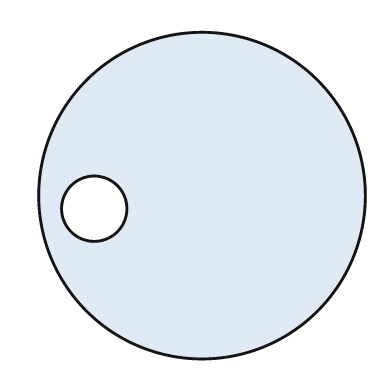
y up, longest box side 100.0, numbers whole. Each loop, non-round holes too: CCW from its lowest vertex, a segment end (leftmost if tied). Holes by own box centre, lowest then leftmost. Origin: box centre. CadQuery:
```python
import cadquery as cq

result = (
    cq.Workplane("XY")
    .moveTo(0.0, 0.0)
    .circle(50.0)
    .moveTo(-33.0, -4.0)
    .circle(10.0)
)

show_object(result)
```